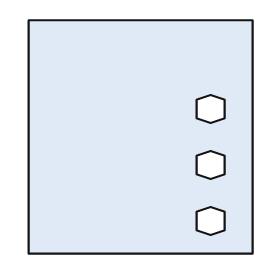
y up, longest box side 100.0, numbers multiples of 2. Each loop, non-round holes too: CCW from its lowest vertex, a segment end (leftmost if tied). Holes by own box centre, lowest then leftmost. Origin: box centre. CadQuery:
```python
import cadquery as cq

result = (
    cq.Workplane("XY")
    .moveTo(-48.0, -50.0)
    .lineTo(48.0, -50.0)
    .lineTo(48.0, 50.0)
    .lineTo(-48.0, 50.0)
    .close()
    .moveTo(30.0, -42.0)
    .lineTo(36.0, -40.0)
    .lineTo(36.0, -32.0)
    .lineTo(30.0, -30.0)
    .lineTo(24.0, -32.0)
    .lineTo(24.0, -40.0)
    .close()
    .moveTo(30.0, -18.0)
    .lineTo(36.0, -16.0)
    .lineTo(36.0, -8.0)
    .lineTo(30.0, -6.0)
    .lineTo(24.0, -8.0)
    .lineTo(24.0, -16.0)
    .close()
    .moveTo(30.0, 6.0)
    .lineTo(36.0, 8.0)
    .lineTo(36.0, 16.0)
    .lineTo(30.0, 18.0)
    .lineTo(24.0, 16.0)
    .lineTo(24.0, 8.0)
    .close()
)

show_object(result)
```